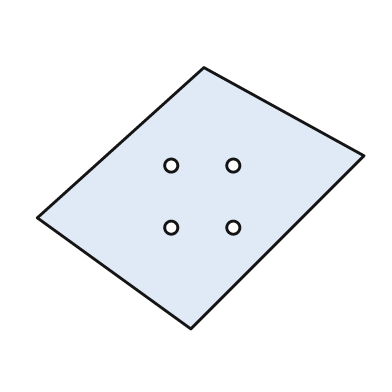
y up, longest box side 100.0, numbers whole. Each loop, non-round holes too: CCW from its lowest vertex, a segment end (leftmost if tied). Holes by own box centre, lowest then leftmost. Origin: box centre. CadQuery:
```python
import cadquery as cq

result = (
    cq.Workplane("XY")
    .moveTo(-3.0, -40.0)
    .lineTo(50.0, 13.0)
    .lineTo(1.0, 40.0)
    .lineTo(-50.0, -6.0)
    .close()
    .moveTo(-9.0, -9.0)
    .circle(2.0)
    .moveTo(10.0, -9.0)
    .circle(2.0)
    .moveTo(-9.0, 10.0)
    .circle(2.0)
    .moveTo(10.0, 10.0)
    .circle(2.0)
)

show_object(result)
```